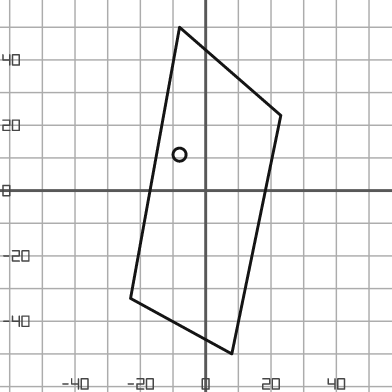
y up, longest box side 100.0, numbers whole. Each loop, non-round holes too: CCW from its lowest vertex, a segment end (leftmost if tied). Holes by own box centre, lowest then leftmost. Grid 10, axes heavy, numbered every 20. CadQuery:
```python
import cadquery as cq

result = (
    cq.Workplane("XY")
    .moveTo(8.0, -50.0)
    .lineTo(23.0, 23.0)
    .lineTo(-8.0, 50.0)
    .lineTo(-23.0, -33.0)
    .close()
    .moveTo(-8.0, 11.0)
    .circle(2.0)
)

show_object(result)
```